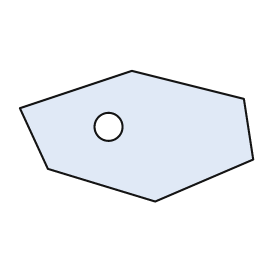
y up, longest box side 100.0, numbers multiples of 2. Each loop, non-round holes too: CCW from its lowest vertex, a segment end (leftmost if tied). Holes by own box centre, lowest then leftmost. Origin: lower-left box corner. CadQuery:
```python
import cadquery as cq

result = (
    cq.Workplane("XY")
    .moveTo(58.0, 0.0)
    .lineTo(100.0, 18.0)
    .lineTo(96.0, 44.0)
    .lineTo(48.0, 56.0)
    .lineTo(0.0, 40.0)
    .lineTo(12.0, 14.0)
    .close()
    .moveTo(38.0, 32.0)
    .circle(6.0)
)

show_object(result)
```